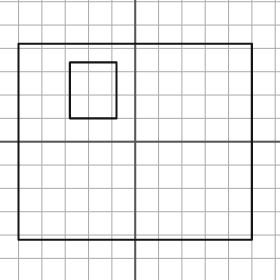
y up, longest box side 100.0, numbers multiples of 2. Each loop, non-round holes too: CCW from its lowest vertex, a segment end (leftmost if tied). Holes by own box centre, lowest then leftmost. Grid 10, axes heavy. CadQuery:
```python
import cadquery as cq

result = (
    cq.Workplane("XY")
    .moveTo(-50.0, -42.0)
    .lineTo(50.0, -42.0)
    .lineTo(50.0, 42.0)
    .lineTo(-50.0, 42.0)
    .close()
    .moveTo(-28.0, 10.0)
    .lineTo(-8.0, 10.0)
    .lineTo(-8.0, 34.0)
    .lineTo(-28.0, 34.0)
    .close()
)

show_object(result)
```